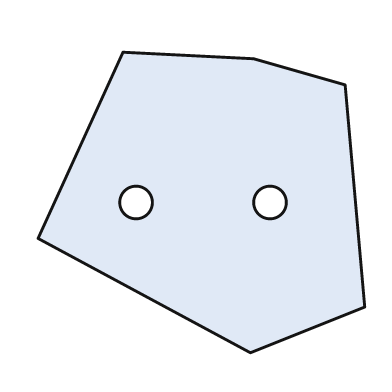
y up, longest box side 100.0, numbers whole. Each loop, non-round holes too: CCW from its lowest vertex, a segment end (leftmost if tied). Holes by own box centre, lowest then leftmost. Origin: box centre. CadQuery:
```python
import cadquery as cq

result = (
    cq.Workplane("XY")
    .moveTo(15.0, -46.0)
    .lineTo(50.0, -32.0)
    .lineTo(44.0, 36.0)
    .lineTo(16.0, 44.0)
    .lineTo(-24.0, 46.0)
    .lineTo(-50.0, -11.0)
    .close()
    .moveTo(-20.0, 0.0)
    .circle(5.0)
    .moveTo(21.0, 0.0)
    .circle(5.0)
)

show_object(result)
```